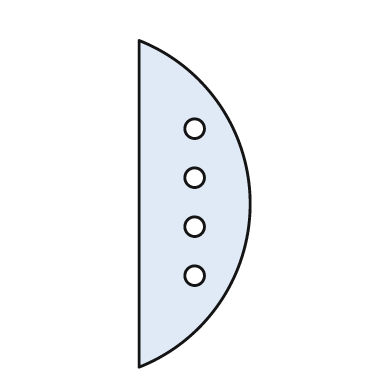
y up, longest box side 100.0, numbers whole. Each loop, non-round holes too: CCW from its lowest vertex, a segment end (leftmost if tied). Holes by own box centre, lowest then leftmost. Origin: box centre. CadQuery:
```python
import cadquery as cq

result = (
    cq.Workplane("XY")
    .moveTo(-17.0, -50.0)
    .threePointArc((17.0, 0.0), (-17.0, 50.0))
    .close()
    .moveTo(0.0, -22.0)
    .circle(3.0)
    .moveTo(0.0, -7.0)
    .circle(3.0)
    .moveTo(0.0, 8.0)
    .circle(3.0)
    .moveTo(0.0, 23.0)
    .circle(3.0)
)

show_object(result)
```